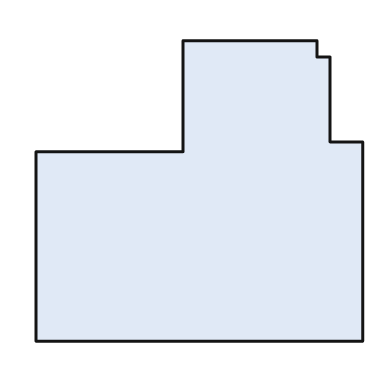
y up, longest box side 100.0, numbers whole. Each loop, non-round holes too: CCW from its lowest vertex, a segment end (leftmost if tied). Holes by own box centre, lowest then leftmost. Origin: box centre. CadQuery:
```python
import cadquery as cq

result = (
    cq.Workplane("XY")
    .moveTo(-50.0, -46.0)
    .lineTo(50.0, -46.0)
    .lineTo(50.0, 15.0)
    .lineTo(40.0, 15.0)
    .lineTo(40.0, 41.0)
    .lineTo(36.0, 41.0)
    .lineTo(36.0, 46.0)
    .lineTo(-5.0, 46.0)
    .lineTo(-5.0, 12.0)
    .lineTo(-50.0, 12.0)
    .close()
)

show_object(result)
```